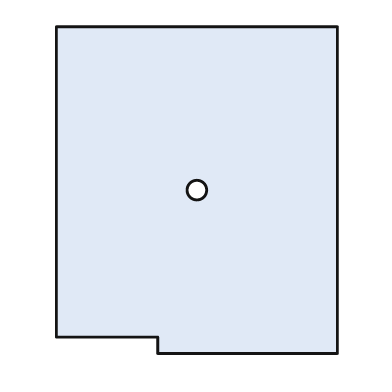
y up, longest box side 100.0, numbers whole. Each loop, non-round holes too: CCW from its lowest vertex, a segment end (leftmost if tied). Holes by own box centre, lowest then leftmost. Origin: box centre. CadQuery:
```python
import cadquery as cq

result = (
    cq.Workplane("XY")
    .moveTo(-12.0, -50.0)
    .lineTo(43.0, -50.0)
    .lineTo(43.0, 50.0)
    .lineTo(-43.0, 50.0)
    .lineTo(-43.0, -45.0)
    .lineTo(-12.0, -45.0)
    .close()
    .moveTo(0.0, 0.0)
    .circle(3.0)
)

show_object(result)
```